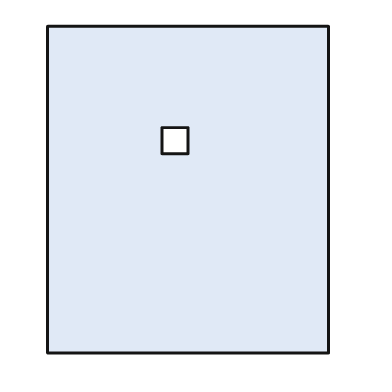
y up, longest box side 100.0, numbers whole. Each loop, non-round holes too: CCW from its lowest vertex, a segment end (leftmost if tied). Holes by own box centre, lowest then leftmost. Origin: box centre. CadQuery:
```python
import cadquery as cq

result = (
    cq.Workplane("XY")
    .moveTo(-43.0, -50.0)
    .lineTo(43.0, -50.0)
    .lineTo(43.0, 50.0)
    .lineTo(-43.0, 50.0)
    .close()
    .moveTo(-8.0, 11.0)
    .lineTo(0.0, 11.0)
    .lineTo(0.0, 19.0)
    .lineTo(-8.0, 19.0)
    .close()
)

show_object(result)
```